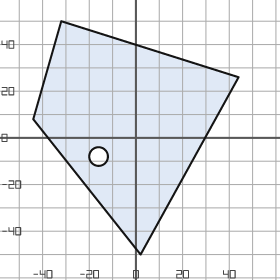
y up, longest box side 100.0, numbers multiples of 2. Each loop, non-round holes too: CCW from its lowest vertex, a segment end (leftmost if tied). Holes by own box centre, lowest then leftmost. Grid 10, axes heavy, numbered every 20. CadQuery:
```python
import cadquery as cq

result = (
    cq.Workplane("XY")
    .moveTo(2.0, -50.0)
    .lineTo(44.0, 26.0)
    .lineTo(-32.0, 50.0)
    .lineTo(-44.0, 8.0)
    .close()
    .moveTo(-16.0, -8.0)
    .circle(4.0)
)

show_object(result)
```